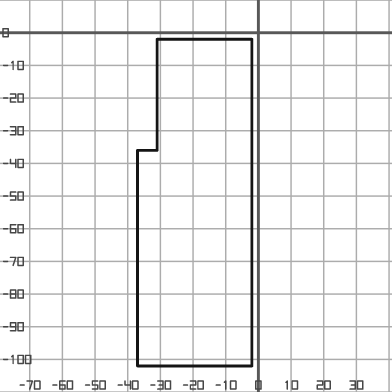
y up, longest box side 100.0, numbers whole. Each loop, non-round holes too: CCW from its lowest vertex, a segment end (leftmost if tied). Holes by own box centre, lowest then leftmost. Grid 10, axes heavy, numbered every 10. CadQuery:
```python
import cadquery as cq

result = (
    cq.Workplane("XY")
    .moveTo(-37.0, -102.0)
    .lineTo(-2.0, -102.0)
    .lineTo(-2.0, -2.0)
    .lineTo(-31.0, -2.0)
    .lineTo(-31.0, -36.0)
    .lineTo(-37.0, -36.0)
    .close()
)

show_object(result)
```